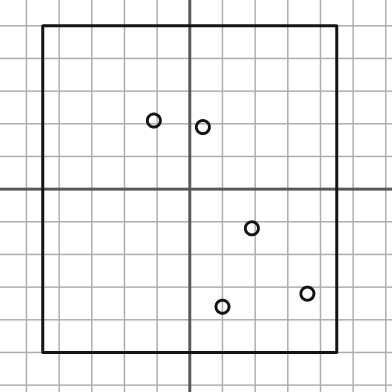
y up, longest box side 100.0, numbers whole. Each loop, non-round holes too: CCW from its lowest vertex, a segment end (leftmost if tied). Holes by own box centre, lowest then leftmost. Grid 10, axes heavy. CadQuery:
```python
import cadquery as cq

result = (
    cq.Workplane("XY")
    .moveTo(-45.0, -50.0)
    .lineTo(45.0, -50.0)
    .lineTo(45.0, 50.0)
    .lineTo(-45.0, 50.0)
    .close()
    .moveTo(10.0, -36.0)
    .circle(2.0)
    .moveTo(36.0, -32.0)
    .circle(2.0)
    .moveTo(19.0, -12.0)
    .circle(2.0)
    .moveTo(4.0, 19.0)
    .circle(2.0)
    .moveTo(-11.0, 21.0)
    .circle(2.0)
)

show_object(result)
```